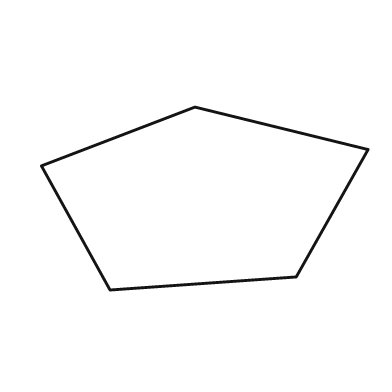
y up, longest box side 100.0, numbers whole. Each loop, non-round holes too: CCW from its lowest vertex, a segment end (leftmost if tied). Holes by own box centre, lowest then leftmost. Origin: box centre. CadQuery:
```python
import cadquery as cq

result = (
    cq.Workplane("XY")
    .moveTo(-29.0, -28.0)
    .lineTo(28.0, -24.0)
    .lineTo(50.0, 15.0)
    .lineTo(-3.0, 28.0)
    .lineTo(-50.0, 10.0)
    .close()
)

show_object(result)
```